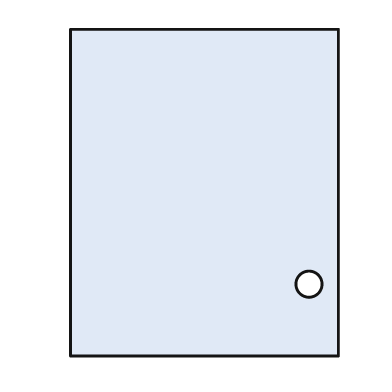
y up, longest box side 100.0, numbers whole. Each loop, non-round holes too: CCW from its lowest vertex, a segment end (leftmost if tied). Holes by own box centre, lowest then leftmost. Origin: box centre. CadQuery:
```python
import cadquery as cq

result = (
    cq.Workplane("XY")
    .moveTo(-41.0, -50.0)
    .lineTo(41.0, -50.0)
    .lineTo(41.0, 50.0)
    .lineTo(-41.0, 50.0)
    .close()
    .moveTo(32.0, -28.0)
    .circle(4.0)
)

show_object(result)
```